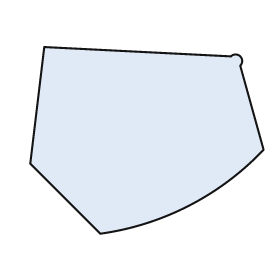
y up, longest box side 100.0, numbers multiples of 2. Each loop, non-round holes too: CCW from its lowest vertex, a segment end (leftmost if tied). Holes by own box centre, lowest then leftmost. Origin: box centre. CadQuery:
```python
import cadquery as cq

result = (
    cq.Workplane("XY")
    .moveTo(-20.0, -40.0)
    .threePointArc((18.0, -28.0), (50.0, -4.0))
    .lineTo(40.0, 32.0)
    .threePointArc((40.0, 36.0), (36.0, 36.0))
    .lineTo(-44.0, 40.0)
    .lineTo(-50.0, -10.0)
    .close()
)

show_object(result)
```